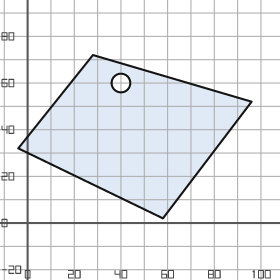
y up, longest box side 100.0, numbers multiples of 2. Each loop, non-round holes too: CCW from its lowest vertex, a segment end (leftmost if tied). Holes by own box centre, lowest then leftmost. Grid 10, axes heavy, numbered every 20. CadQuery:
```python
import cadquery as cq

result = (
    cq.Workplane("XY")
    .moveTo(58.0, 2.0)
    .lineTo(96.0, 52.0)
    .lineTo(28.0, 72.0)
    .lineTo(-4.0, 32.0)
    .close()
    .moveTo(40.0, 60.0)
    .circle(4.0)
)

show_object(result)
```